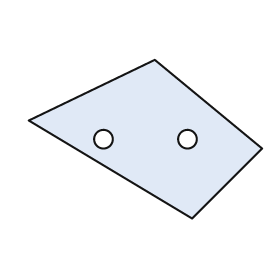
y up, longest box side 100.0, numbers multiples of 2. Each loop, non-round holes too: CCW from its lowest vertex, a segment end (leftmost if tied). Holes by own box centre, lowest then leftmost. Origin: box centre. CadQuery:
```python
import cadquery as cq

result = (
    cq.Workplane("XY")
    .moveTo(20.0, -34.0)
    .lineTo(50.0, -4.0)
    .lineTo(4.0, 34.0)
    .lineTo(-50.0, 8.0)
    .close()
    .moveTo(-18.0, 0.0)
    .circle(4.0)
    .moveTo(18.0, 0.0)
    .circle(4.0)
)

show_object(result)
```